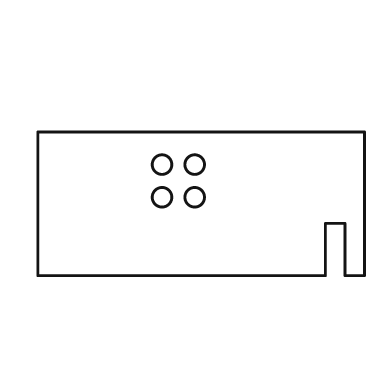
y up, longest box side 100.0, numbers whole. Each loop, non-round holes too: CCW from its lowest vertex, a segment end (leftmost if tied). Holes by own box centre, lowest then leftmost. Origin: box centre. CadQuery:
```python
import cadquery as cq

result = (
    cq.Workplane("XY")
    .moveTo(-50.0, -22.0)
    .lineTo(38.0, -22.0)
    .lineTo(38.0, -6.0)
    .lineTo(44.0, -6.0)
    .lineTo(44.0, -22.0)
    .lineTo(50.0, -22.0)
    .lineTo(50.0, 22.0)
    .lineTo(-50.0, 22.0)
    .close()
    .moveTo(-12.0, 2.0)
    .circle(3.0)
    .moveTo(-2.0, 2.0)
    .circle(3.0)
    .moveTo(-12.0, 12.0)
    .circle(3.0)
    .moveTo(-2.0, 12.0)
    .circle(3.0)
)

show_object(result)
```